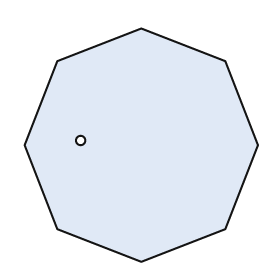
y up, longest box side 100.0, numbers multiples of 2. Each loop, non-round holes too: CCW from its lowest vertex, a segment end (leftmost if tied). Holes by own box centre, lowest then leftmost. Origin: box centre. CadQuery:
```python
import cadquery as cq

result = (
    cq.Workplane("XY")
    .moveTo(0.0, -50.0)
    .lineTo(36.0, -36.0)
    .lineTo(50.0, 0.0)
    .lineTo(36.0, 36.0)
    .lineTo(0.0, 50.0)
    .lineTo(-36.0, 36.0)
    .lineTo(-50.0, 0.0)
    .lineTo(-36.0, -36.0)
    .close()
    .moveTo(-26.0, 2.0)
    .circle(2.0)
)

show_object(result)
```